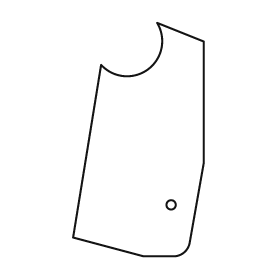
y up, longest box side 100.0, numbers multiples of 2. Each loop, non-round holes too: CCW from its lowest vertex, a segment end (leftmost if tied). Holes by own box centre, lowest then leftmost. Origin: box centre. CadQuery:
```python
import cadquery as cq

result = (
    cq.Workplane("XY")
    .moveTo(2.0, -50.0)
    .lineTo(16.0, -50.0)
    .threePointArc((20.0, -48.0), (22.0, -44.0))
    .lineTo(28.0, -10.0)
    .lineTo(28.0, 42.0)
    .lineTo(8.0, 50.0)
    .threePointArc((4.0, 30.0), (-16.0, 32.0))
    .lineTo(-28.0, -42.0)
    .close()
    .moveTo(14.0, -28.0)
    .circle(2.0)
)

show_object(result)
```